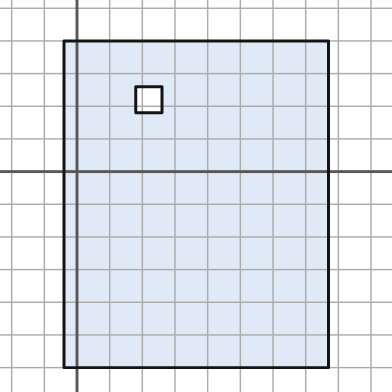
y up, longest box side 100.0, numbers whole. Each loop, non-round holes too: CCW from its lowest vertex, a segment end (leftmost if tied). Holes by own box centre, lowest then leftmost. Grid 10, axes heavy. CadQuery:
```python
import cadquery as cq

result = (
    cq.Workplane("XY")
    .moveTo(-4.0, -60.0)
    .lineTo(77.0, -60.0)
    .lineTo(77.0, 40.0)
    .lineTo(-4.0, 40.0)
    .close()
    .moveTo(18.0, 18.0)
    .lineTo(26.0, 18.0)
    .lineTo(26.0, 26.0)
    .lineTo(18.0, 26.0)
    .close()
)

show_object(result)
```